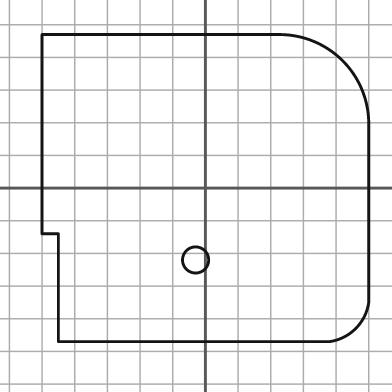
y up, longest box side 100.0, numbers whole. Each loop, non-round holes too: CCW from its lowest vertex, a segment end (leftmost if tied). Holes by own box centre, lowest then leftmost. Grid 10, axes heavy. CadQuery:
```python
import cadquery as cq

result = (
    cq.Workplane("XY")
    .moveTo(-45.0, -47.0)
    .lineTo(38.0, -47.0)
    .threePointArc((46.0, -43.0), (50.0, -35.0))
    .lineTo(50.0, 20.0)
    .threePointArc((42.0, 39.0), (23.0, 47.0))
    .lineTo(-50.0, 47.0)
    .lineTo(-50.0, -14.0)
    .lineTo(-45.0, -14.0)
    .close()
    .moveTo(-3.0, -22.0)
    .circle(4.0)
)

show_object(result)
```